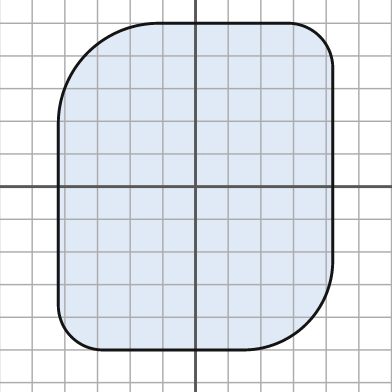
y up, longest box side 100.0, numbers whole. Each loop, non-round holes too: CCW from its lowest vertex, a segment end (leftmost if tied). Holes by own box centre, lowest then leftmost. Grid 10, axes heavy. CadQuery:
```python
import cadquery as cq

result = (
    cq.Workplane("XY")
    .moveTo(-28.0, -50.0)
    .lineTo(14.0, -50.0)
    .threePointArc((34.0, -42.0), (42.0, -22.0))
    .lineTo(42.0, 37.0)
    .threePointArc((38.0, 46.0), (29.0, 50.0))
    .lineTo(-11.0, 50.0)
    .threePointArc((-33.0, 41.0), (-42.0, 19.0))
    .lineTo(-42.0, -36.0)
    .threePointArc((-38.0, -46.0), (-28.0, -50.0))
    .close()
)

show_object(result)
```